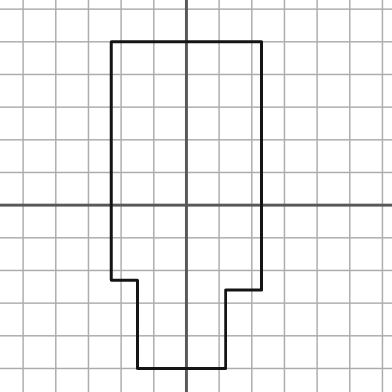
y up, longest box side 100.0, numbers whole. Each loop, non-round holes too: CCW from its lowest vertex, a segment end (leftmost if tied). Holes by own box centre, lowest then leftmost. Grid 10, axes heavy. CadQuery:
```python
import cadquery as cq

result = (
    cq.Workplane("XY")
    .moveTo(-15.0, -50.0)
    .lineTo(12.0, -50.0)
    .lineTo(12.0, -26.0)
    .lineTo(23.0, -26.0)
    .lineTo(23.0, 50.0)
    .lineTo(-23.0, 50.0)
    .lineTo(-23.0, -23.0)
    .lineTo(-15.0, -23.0)
    .close()
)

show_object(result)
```